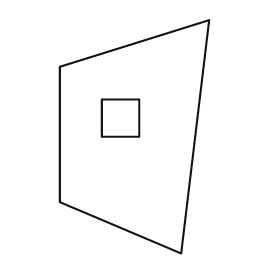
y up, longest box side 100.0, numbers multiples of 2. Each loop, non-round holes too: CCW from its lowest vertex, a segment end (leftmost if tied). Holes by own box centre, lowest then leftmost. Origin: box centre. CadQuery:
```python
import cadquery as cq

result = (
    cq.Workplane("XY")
    .moveTo(20.0, -50.0)
    .lineTo(32.0, 50.0)
    .lineTo(-32.0, 30.0)
    .lineTo(-32.0, -28.0)
    .close()
    .moveTo(-14.0, 0.0)
    .lineTo(2.0, 0.0)
    .lineTo(2.0, 16.0)
    .lineTo(-14.0, 16.0)
    .close()
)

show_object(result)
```